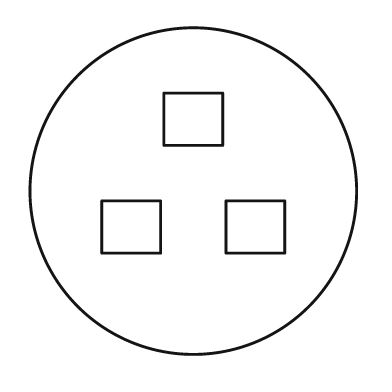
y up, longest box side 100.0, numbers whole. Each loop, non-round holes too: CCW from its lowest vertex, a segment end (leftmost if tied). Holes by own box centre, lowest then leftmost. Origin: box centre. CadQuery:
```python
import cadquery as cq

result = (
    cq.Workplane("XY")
    .moveTo(0.0, 0.0)
    .circle(50.0)
    .moveTo(-28.0, -19.0)
    .lineTo(-10.0, -19.0)
    .lineTo(-10.0, -3.0)
    .lineTo(-28.0, -3.0)
    .close()
    .moveTo(10.0, -19.0)
    .lineTo(28.0, -19.0)
    .lineTo(28.0, -3.0)
    .lineTo(10.0, -3.0)
    .close()
    .moveTo(-9.0, 14.0)
    .lineTo(9.0, 14.0)
    .lineTo(9.0, 30.0)
    .lineTo(-9.0, 30.0)
    .close()
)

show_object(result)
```